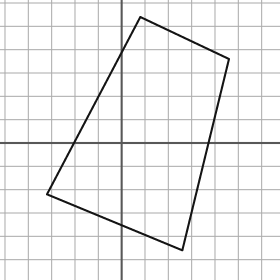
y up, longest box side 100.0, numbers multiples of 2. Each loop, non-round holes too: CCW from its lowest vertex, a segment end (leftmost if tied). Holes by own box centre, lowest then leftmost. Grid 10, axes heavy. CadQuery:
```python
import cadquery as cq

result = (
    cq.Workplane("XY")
    .moveTo(26.0, -46.0)
    .lineTo(46.0, 36.0)
    .lineTo(8.0, 54.0)
    .lineTo(-32.0, -22.0)
    .close()
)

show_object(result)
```